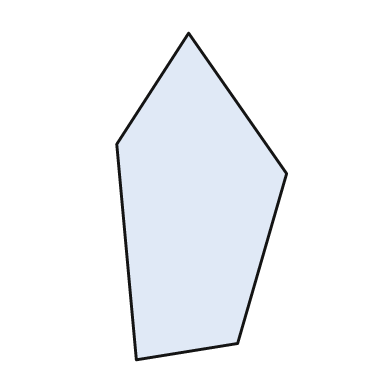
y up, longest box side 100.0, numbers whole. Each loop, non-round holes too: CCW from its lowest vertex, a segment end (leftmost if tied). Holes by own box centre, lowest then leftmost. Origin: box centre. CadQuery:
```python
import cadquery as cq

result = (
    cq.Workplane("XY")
    .moveTo(-20.0, -50.0)
    .lineTo(11.0, -45.0)
    .lineTo(26.0, 7.0)
    .lineTo(-4.0, 50.0)
    .lineTo(-26.0, 16.0)
    .close()
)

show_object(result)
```